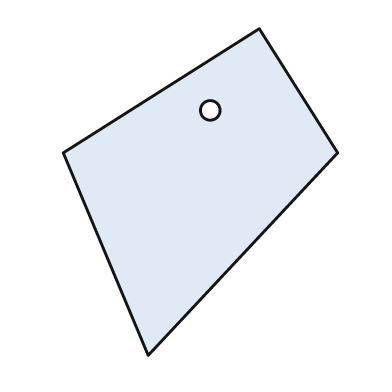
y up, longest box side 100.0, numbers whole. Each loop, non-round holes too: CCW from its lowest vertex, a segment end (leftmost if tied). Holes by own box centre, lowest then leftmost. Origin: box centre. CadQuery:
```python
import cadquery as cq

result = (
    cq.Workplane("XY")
    .moveTo(-16.0, -50.0)
    .lineTo(42.0, 12.0)
    .lineTo(18.0, 50.0)
    .lineTo(-42.0, 12.0)
    .close()
    .moveTo(3.0, 25.0)
    .circle(3.0)
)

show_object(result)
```